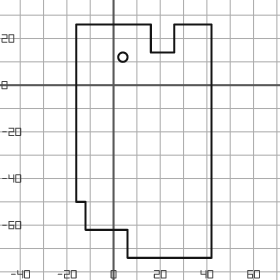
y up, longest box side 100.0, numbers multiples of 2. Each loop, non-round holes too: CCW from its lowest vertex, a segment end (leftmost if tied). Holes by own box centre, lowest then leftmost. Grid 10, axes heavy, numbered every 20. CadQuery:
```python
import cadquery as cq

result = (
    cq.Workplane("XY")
    .moveTo(6.0, -74.0)
    .lineTo(42.0, -74.0)
    .lineTo(42.0, 26.0)
    .lineTo(26.0, 26.0)
    .lineTo(26.0, 14.0)
    .lineTo(16.0, 14.0)
    .lineTo(16.0, 26.0)
    .lineTo(-16.0, 26.0)
    .lineTo(-16.0, -50.0)
    .lineTo(-12.0, -50.0)
    .lineTo(-12.0, -62.0)
    .lineTo(6.0, -62.0)
    .close()
    .moveTo(4.0, 12.0)
    .circle(2.0)
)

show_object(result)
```